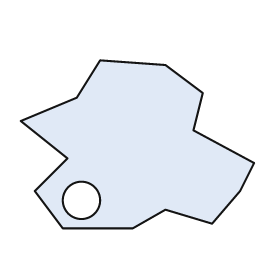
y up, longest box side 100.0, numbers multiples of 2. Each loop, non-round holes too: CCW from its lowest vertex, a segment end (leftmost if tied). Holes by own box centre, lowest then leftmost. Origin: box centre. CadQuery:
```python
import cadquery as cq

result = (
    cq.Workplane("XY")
    .moveTo(-32.0, -36.0)
    .lineTo(-2.0, -36.0)
    .lineTo(12.0, -28.0)
    .lineTo(32.0, -34.0)
    .lineTo(44.0, -20.0)
    .lineTo(50.0, -8.0)
    .lineTo(24.0, 6.0)
    .lineTo(28.0, 22.0)
    .lineTo(12.0, 34.0)
    .lineTo(-16.0, 36.0)
    .lineTo(-26.0, 20.0)
    .lineTo(-50.0, 10.0)
    .lineTo(-30.0, -6.0)
    .lineTo(-44.0, -20.0)
    .close()
    .moveTo(-24.0, -24.0)
    .circle(8.0)
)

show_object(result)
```